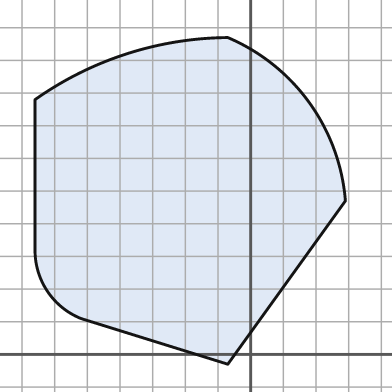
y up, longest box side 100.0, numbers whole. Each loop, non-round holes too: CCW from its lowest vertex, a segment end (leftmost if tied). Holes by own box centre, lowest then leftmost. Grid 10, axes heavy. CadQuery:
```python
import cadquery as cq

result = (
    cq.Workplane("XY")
    .moveTo(-7.0, -3.0)
    .lineTo(29.0, 47.0)
    .threePointArc((18.0, 77.0), (-7.0, 97.0))
    .threePointArc((-38.0, 92.0), (-66.0, 78.0))
    .lineTo(-66.0, 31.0)
    .threePointArc((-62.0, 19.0), (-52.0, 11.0))
    .close()
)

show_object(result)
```